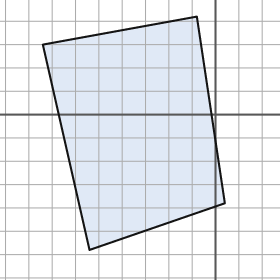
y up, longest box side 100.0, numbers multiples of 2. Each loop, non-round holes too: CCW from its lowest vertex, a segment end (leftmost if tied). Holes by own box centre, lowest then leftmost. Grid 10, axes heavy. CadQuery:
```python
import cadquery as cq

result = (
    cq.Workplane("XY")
    .moveTo(-54.0, -58.0)
    .lineTo(4.0, -38.0)
    .lineTo(-8.0, 42.0)
    .lineTo(-74.0, 30.0)
    .close()
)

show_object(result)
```